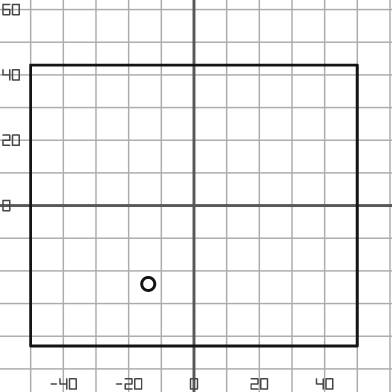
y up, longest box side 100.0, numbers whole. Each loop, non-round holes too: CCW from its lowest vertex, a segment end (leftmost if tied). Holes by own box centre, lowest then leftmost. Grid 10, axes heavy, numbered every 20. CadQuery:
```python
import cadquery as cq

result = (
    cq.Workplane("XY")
    .moveTo(-50.0, -43.0)
    .lineTo(50.0, -43.0)
    .lineTo(50.0, 43.0)
    .lineTo(-50.0, 43.0)
    .close()
    .moveTo(-14.0, -24.0)
    .circle(2.0)
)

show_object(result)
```